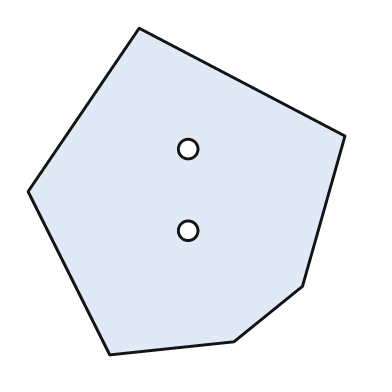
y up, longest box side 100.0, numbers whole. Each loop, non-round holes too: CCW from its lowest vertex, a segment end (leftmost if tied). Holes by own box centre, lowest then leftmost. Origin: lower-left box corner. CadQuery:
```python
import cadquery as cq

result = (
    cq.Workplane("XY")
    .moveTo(25.0, 0.0)
    .lineTo(63.0, 4.0)
    .lineTo(84.0, 21.0)
    .lineTo(97.0, 67.0)
    .lineTo(34.0, 100.0)
    .lineTo(0.0, 50.0)
    .close()
    .moveTo(49.0, 38.0)
    .circle(3.0)
    .moveTo(49.0, 63.0)
    .circle(3.0)
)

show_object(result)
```